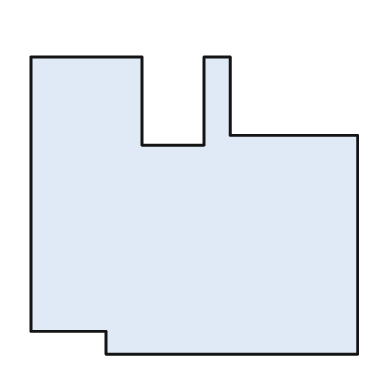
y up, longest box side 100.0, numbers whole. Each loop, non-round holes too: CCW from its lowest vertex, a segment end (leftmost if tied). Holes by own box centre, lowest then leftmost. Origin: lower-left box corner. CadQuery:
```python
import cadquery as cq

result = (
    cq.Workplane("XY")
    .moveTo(23.0, 0.0)
    .lineTo(100.0, 0.0)
    .lineTo(100.0, 67.0)
    .lineTo(61.0, 67.0)
    .lineTo(61.0, 91.0)
    .lineTo(53.0, 91.0)
    .lineTo(53.0, 64.0)
    .lineTo(34.0, 64.0)
    .lineTo(34.0, 91.0)
    .lineTo(0.0, 91.0)
    .lineTo(0.0, 7.0)
    .lineTo(23.0, 7.0)
    .close()
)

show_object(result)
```